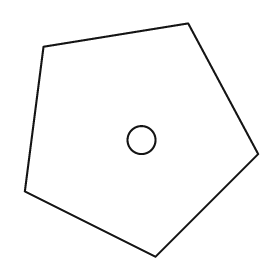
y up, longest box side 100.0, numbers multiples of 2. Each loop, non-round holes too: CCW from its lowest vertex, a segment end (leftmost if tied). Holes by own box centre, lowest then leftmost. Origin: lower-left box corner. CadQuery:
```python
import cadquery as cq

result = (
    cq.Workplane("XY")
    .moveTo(56.0, 0.0)
    .lineTo(100.0, 44.0)
    .lineTo(70.0, 100.0)
    .lineTo(8.0, 90.0)
    .lineTo(0.0, 28.0)
    .close()
    .moveTo(50.0, 50.0)
    .circle(6.0)
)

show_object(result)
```